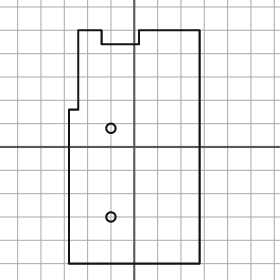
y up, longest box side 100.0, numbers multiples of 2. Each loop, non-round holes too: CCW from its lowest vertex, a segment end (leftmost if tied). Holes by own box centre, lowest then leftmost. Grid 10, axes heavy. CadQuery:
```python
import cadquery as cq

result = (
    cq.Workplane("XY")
    .moveTo(-28.0, -50.0)
    .lineTo(28.0, -50.0)
    .lineTo(28.0, 50.0)
    .lineTo(2.0, 50.0)
    .lineTo(2.0, 44.0)
    .lineTo(-14.0, 44.0)
    .lineTo(-14.0, 50.0)
    .lineTo(-24.0, 50.0)
    .lineTo(-24.0, 16.0)
    .lineTo(-28.0, 16.0)
    .close()
    .moveTo(-10.0, -30.0)
    .circle(2.0)
    .moveTo(-10.0, 8.0)
    .circle(2.0)
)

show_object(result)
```